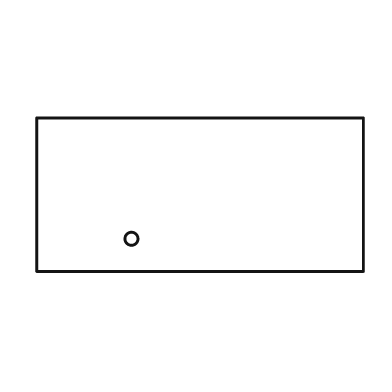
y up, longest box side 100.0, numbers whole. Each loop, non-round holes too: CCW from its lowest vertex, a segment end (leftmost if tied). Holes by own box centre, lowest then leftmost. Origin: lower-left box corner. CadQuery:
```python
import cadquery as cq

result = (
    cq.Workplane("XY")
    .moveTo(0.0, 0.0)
    .lineTo(100.0, 0.0)
    .lineTo(100.0, 47.0)
    .lineTo(0.0, 47.0)
    .close()
    .moveTo(29.0, 10.0)
    .circle(2.0)
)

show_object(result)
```